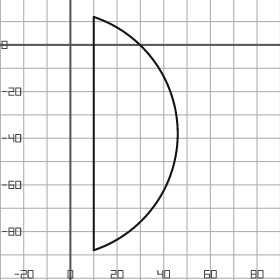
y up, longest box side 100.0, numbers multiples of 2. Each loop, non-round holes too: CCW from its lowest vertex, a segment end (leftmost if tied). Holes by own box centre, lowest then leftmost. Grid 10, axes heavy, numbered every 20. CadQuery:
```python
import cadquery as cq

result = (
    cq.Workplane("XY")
    .moveTo(10.0, -88.0)
    .threePointArc((46.0, -38.0), (10.0, 12.0))
    .close()
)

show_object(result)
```